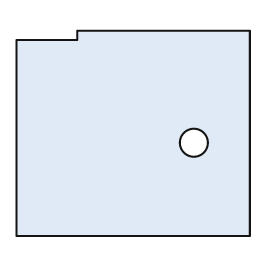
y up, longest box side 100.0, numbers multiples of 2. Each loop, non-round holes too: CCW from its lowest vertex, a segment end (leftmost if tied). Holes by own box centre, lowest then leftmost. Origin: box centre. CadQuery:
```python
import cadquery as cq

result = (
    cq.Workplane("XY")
    .moveTo(-50.0, -44.0)
    .lineTo(50.0, -44.0)
    .lineTo(50.0, 44.0)
    .lineTo(-24.0, 44.0)
    .lineTo(-24.0, 40.0)
    .lineTo(-50.0, 40.0)
    .close()
    .moveTo(26.0, -4.0)
    .circle(6.0)
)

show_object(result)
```